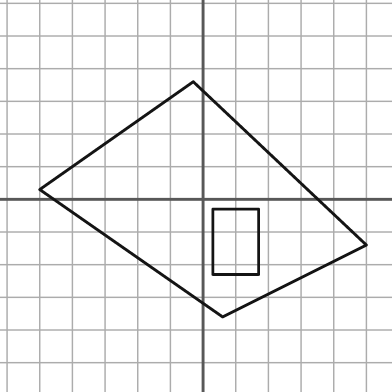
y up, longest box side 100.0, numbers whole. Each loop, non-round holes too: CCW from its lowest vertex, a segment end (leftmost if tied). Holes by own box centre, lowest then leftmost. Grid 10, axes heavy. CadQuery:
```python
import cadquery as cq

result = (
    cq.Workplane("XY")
    .moveTo(6.0, -36.0)
    .lineTo(50.0, -14.0)
    .lineTo(-3.0, 36.0)
    .lineTo(-50.0, 3.0)
    .close()
    .moveTo(3.0, -23.0)
    .lineTo(17.0, -23.0)
    .lineTo(17.0, -3.0)
    .lineTo(3.0, -3.0)
    .close()
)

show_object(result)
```